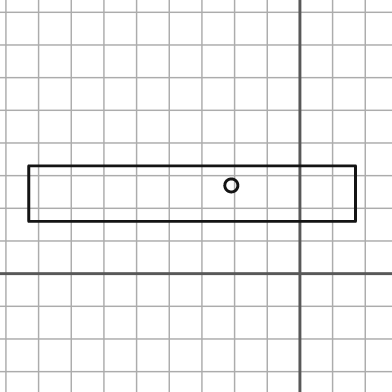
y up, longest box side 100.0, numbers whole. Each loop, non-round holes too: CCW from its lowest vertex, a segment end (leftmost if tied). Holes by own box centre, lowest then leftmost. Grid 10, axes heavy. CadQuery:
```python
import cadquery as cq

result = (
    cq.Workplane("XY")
    .moveTo(-83.0, 16.0)
    .lineTo(17.0, 16.0)
    .lineTo(17.0, 33.0)
    .lineTo(-83.0, 33.0)
    .close()
    .moveTo(-21.0, 27.0)
    .circle(2.0)
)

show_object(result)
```